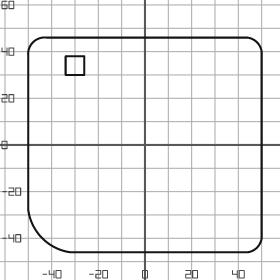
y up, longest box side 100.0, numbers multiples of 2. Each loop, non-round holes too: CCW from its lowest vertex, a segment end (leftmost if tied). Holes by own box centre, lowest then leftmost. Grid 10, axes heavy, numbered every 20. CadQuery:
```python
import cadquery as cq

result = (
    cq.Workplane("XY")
    .moveTo(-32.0, -46.0)
    .lineTo(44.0, -46.0)
    .threePointArc((48.0, -44.0), (50.0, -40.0))
    .lineTo(50.0, 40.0)
    .threePointArc((48.0, 44.0), (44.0, 46.0))
    .lineTo(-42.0, 46.0)
    .threePointArc((-48.0, 44.0), (-50.0, 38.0))
    .lineTo(-50.0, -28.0)
    .threePointArc((-44.0, -40.0), (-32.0, -46.0))
    .close()
    .moveTo(-34.0, 30.0)
    .lineTo(-26.0, 30.0)
    .lineTo(-26.0, 38.0)
    .lineTo(-34.0, 38.0)
    .close()
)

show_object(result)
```